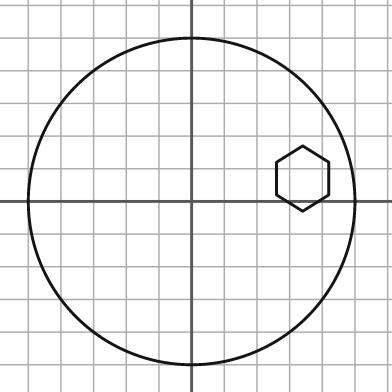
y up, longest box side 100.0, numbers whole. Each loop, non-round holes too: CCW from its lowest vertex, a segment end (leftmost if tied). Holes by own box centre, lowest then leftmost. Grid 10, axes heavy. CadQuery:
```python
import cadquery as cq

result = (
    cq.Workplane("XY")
    .moveTo(0.0, 0.0)
    .circle(50.0)
    .moveTo(34.0, -3.0)
    .lineTo(42.0, 2.0)
    .lineTo(42.0, 12.0)
    .lineTo(34.0, 17.0)
    .lineTo(26.0, 12.0)
    .lineTo(26.0, 2.0)
    .close()
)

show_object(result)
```